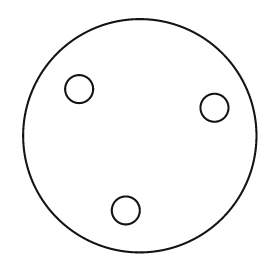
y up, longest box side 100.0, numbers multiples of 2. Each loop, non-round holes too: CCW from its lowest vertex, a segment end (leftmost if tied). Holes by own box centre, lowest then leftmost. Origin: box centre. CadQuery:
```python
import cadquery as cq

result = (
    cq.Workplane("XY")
    .moveTo(0.0, 0.0)
    .circle(50.0)
    .moveTo(-6.0, -32.0)
    .circle(6.0)
    .moveTo(32.0, 12.0)
    .circle(6.0)
    .moveTo(-26.0, 20.0)
    .circle(6.0)
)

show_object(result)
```